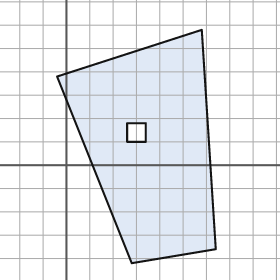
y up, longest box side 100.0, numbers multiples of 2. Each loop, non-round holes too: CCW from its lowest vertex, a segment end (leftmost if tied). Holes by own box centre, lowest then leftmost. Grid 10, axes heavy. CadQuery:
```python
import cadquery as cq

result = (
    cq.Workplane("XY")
    .moveTo(28.0, -42.0)
    .lineTo(64.0, -36.0)
    .lineTo(58.0, 58.0)
    .lineTo(-4.0, 38.0)
    .close()
    .moveTo(26.0, 10.0)
    .lineTo(34.0, 10.0)
    .lineTo(34.0, 18.0)
    .lineTo(26.0, 18.0)
    .close()
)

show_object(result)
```